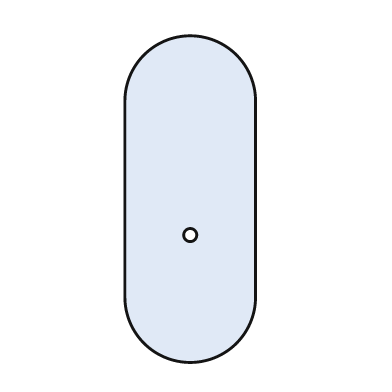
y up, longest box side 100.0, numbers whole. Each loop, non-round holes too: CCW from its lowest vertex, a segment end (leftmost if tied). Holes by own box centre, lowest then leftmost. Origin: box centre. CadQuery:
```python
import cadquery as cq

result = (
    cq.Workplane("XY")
    .moveTo(-20.0, -30.0)
    .threePointArc((0.0, -50.0), (20.0, -30.0))
    .lineTo(20.0, 30.0)
    .threePointArc((0.0, 50.0), (-20.0, 30.0))
    .close()
    .moveTo(0.0, -11.0)
    .circle(2.0)
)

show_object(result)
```